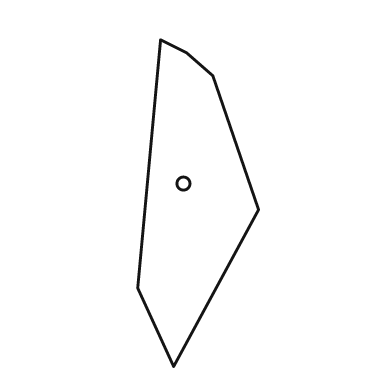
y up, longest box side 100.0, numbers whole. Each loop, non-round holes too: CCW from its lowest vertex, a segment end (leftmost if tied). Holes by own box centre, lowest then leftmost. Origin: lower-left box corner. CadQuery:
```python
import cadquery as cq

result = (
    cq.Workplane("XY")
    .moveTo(11.0, 0.0)
    .lineTo(37.0, 48.0)
    .lineTo(23.0, 89.0)
    .lineTo(15.0, 96.0)
    .lineTo(7.0, 100.0)
    .lineTo(0.0, 24.0)
    .close()
    .moveTo(14.0, 56.0)
    .circle(2.0)
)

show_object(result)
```